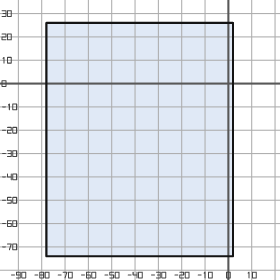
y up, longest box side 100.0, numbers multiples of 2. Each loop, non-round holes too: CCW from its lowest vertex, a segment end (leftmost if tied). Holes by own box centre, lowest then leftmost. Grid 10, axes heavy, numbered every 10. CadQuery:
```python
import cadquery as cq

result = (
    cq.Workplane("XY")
    .moveTo(-78.0, -74.0)
    .lineTo(2.0, -74.0)
    .lineTo(2.0, 26.0)
    .lineTo(-78.0, 26.0)
    .close()
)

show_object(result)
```